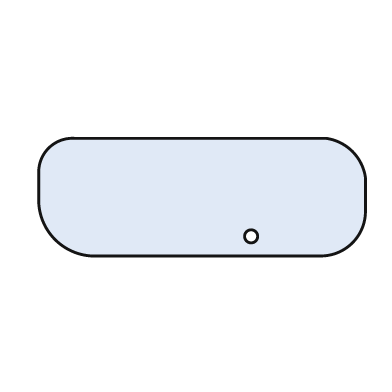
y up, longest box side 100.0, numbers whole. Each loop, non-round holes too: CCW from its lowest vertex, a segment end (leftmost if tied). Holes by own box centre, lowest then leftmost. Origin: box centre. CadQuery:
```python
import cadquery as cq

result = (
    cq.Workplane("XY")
    .moveTo(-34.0, -18.0)
    .lineTo(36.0, -18.0)
    .threePointArc((46.0, -14.0), (50.0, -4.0))
    .lineTo(50.0, 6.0)
    .threePointArc((46.0, 14.0), (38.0, 18.0))
    .lineTo(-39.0, 18.0)
    .threePointArc((-47.0, 15.0), (-50.0, 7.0))
    .lineTo(-50.0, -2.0)
    .threePointArc((-45.0, -13.0), (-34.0, -18.0))
    .close()
    .moveTo(15.0, -12.0)
    .circle(2.0)
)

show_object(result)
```